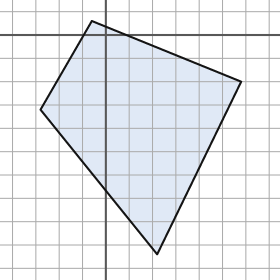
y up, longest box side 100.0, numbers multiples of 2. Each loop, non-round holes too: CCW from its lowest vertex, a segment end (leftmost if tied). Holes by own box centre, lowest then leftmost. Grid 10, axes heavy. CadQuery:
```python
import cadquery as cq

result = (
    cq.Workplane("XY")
    .moveTo(22.0, -94.0)
    .lineTo(58.0, -20.0)
    .lineTo(-6.0, 6.0)
    .lineTo(-28.0, -32.0)
    .close()
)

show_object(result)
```